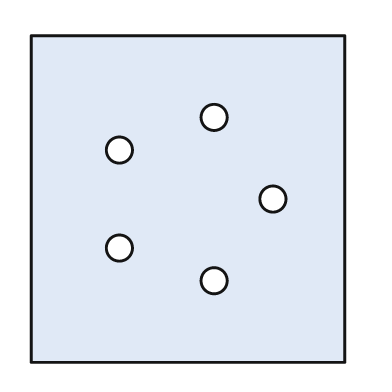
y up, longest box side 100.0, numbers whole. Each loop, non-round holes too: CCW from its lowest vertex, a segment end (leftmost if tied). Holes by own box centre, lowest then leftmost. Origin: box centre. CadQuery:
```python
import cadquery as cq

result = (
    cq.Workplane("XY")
    .moveTo(-48.0, -50.0)
    .lineTo(48.0, -50.0)
    .lineTo(48.0, 50.0)
    .lineTo(-48.0, 50.0)
    .close()
    .moveTo(8.0, -25.0)
    .circle(4.0)
    .moveTo(-21.0, -15.0)
    .circle(4.0)
    .moveTo(26.0, 0.0)
    .circle(4.0)
    .moveTo(-21.0, 15.0)
    .circle(4.0)
    .moveTo(8.0, 25.0)
    .circle(4.0)
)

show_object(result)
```